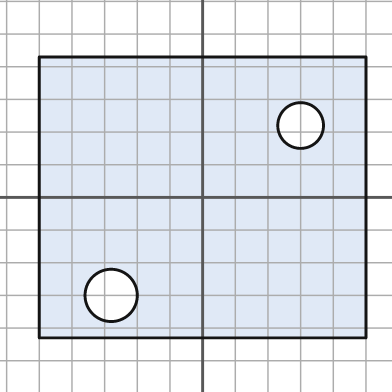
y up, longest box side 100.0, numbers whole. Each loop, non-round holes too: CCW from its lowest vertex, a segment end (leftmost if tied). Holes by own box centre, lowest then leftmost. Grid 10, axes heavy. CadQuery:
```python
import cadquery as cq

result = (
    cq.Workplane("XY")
    .moveTo(-50.0, -43.0)
    .lineTo(50.0, -43.0)
    .lineTo(50.0, 43.0)
    .lineTo(-50.0, 43.0)
    .close()
    .moveTo(-28.0, -30.0)
    .circle(8.0)
    .moveTo(30.0, 22.0)
    .circle(7.0)
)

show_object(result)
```